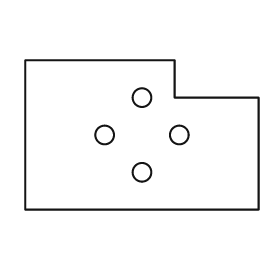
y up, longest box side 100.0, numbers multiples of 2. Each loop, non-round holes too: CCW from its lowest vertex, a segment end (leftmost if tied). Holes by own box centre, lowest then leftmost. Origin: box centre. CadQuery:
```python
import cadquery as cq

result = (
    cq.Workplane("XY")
    .moveTo(-50.0, -32.0)
    .lineTo(50.0, -32.0)
    .lineTo(50.0, 16.0)
    .lineTo(14.0, 16.0)
    .lineTo(14.0, 32.0)
    .lineTo(-50.0, 32.0)
    .close()
    .moveTo(0.0, -16.0)
    .circle(4.0)
    .moveTo(-16.0, 0.0)
    .circle(4.0)
    .moveTo(16.0, 0.0)
    .circle(4.0)
    .moveTo(0.0, 16.0)
    .circle(4.0)
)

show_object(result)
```